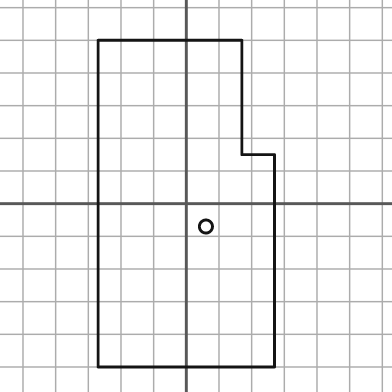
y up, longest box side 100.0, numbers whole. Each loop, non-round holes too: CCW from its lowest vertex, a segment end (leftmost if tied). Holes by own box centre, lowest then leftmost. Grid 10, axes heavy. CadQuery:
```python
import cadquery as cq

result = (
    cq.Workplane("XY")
    .moveTo(-27.0, -50.0)
    .lineTo(27.0, -50.0)
    .lineTo(27.0, 15.0)
    .lineTo(17.0, 15.0)
    .lineTo(17.0, 50.0)
    .lineTo(-27.0, 50.0)
    .close()
    .moveTo(6.0, -7.0)
    .circle(2.0)
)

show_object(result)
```